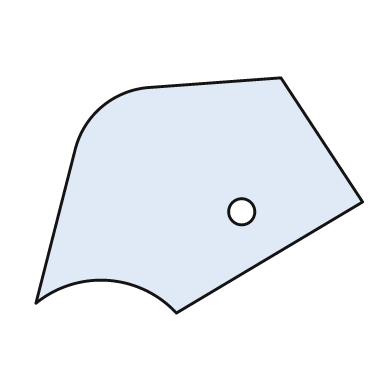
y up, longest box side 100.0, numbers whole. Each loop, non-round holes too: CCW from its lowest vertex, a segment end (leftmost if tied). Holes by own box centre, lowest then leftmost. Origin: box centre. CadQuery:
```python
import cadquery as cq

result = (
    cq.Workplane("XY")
    .moveTo(-7.0, -36.0)
    .lineTo(50.0, -2.0)
    .lineTo(25.0, 36.0)
    .lineTo(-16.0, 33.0)
    .threePointArc((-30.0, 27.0), (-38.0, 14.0))
    .lineTo(-50.0, -33.0)
    .threePointArc((-28.0, -26.0), (-7.0, -36.0))
    .close()
    .moveTo(13.0, -5.0)
    .circle(4.0)
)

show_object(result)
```